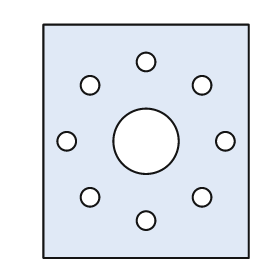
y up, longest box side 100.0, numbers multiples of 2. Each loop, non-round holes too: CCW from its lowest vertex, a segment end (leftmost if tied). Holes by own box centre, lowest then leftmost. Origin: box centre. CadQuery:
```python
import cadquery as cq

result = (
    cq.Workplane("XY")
    .moveTo(-44.0, -50.0)
    .lineTo(44.0, -50.0)
    .lineTo(44.0, 50.0)
    .lineTo(-44.0, 50.0)
    .close()
    .moveTo(0.0, -34.0)
    .circle(4.0)
    .moveTo(-24.0, -24.0)
    .circle(4.0)
    .moveTo(24.0, -24.0)
    .circle(4.0)
    .moveTo(-34.0, 0.0)
    .circle(4.0)
    .moveTo(0.0, 0.0)
    .circle(14.0)
    .moveTo(34.0, 0.0)
    .circle(4.0)
    .moveTo(-24.0, 24.0)
    .circle(4.0)
    .moveTo(24.0, 24.0)
    .circle(4.0)
    .moveTo(0.0, 34.0)
    .circle(4.0)
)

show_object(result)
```